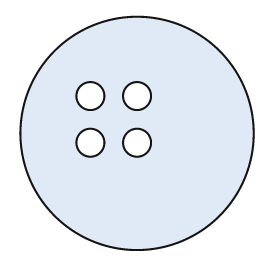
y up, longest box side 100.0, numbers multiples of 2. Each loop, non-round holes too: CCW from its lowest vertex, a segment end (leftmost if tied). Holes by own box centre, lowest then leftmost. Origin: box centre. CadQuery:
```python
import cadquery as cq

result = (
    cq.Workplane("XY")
    .moveTo(0.0, 0.0)
    .circle(50.0)
    .moveTo(-20.0, -4.0)
    .circle(6.0)
    .moveTo(0.0, -4.0)
    .circle(6.0)
    .moveTo(-20.0, 16.0)
    .circle(6.0)
    .moveTo(0.0, 16.0)
    .circle(6.0)
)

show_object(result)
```